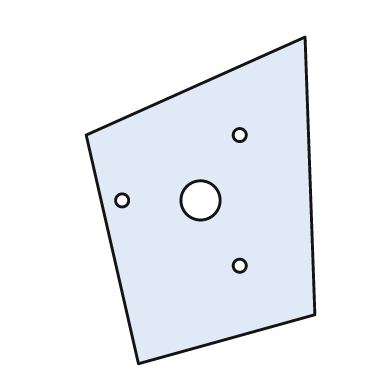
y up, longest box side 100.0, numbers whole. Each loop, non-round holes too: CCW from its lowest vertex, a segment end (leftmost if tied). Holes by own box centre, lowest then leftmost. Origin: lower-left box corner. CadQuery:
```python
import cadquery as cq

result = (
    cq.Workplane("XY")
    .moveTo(16.0, 0.0)
    .lineTo(70.0, 15.0)
    .lineTo(67.0, 100.0)
    .lineTo(0.0, 70.0)
    .close()
    .moveTo(47.0, 30.0)
    .circle(2.0)
    .moveTo(11.0, 50.0)
    .circle(2.0)
    .moveTo(35.0, 50.0)
    .circle(6.0)
    .moveTo(47.0, 70.0)
    .circle(2.0)
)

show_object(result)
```